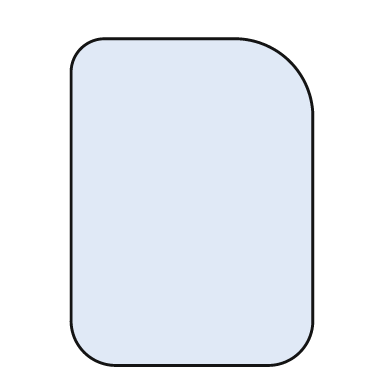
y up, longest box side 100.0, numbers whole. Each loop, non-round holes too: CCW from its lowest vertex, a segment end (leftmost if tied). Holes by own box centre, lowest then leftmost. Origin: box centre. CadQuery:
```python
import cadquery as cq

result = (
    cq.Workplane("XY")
    .moveTo(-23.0, -50.0)
    .lineTo(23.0, -50.0)
    .threePointArc((33.0, -46.0), (37.0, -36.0))
    .lineTo(37.0, 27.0)
    .threePointArc((30.0, 43.0), (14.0, 50.0))
    .lineTo(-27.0, 50.0)
    .threePointArc((-34.0, 47.0), (-37.0, 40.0))
    .lineTo(-37.0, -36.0)
    .threePointArc((-33.0, -46.0), (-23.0, -50.0))
    .close()
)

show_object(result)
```